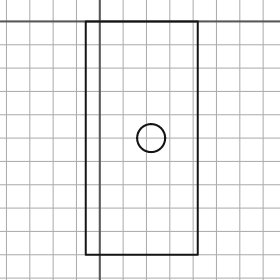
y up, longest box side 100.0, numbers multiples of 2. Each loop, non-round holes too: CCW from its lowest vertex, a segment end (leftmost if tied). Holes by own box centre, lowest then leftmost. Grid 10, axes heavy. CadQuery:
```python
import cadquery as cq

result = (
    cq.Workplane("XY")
    .moveTo(-6.0, -100.0)
    .lineTo(42.0, -100.0)
    .lineTo(42.0, 0.0)
    .lineTo(-6.0, 0.0)
    .close()
    .moveTo(22.0, -50.0)
    .circle(6.0)
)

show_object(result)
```